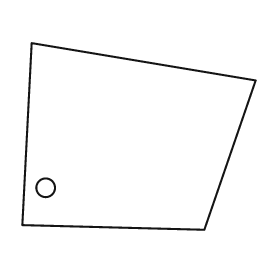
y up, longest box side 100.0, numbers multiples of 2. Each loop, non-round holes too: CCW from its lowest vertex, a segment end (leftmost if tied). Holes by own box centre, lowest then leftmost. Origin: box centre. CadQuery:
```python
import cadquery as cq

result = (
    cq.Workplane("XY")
    .moveTo(28.0, -40.0)
    .lineTo(50.0, 24.0)
    .lineTo(-46.0, 40.0)
    .lineTo(-50.0, -38.0)
    .close()
    .moveTo(-40.0, -22.0)
    .circle(4.0)
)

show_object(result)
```